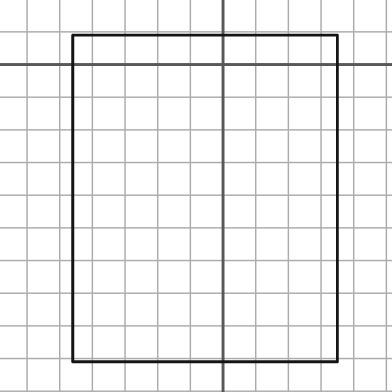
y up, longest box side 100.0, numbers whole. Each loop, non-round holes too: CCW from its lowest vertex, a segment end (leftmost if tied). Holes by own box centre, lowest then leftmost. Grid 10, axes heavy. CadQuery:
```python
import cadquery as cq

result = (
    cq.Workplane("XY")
    .moveTo(-46.0, -91.0)
    .lineTo(35.0, -91.0)
    .lineTo(35.0, 9.0)
    .lineTo(-46.0, 9.0)
    .close()
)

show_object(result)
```